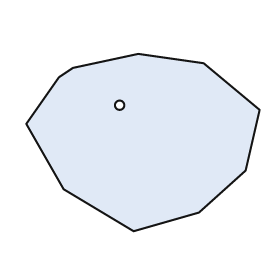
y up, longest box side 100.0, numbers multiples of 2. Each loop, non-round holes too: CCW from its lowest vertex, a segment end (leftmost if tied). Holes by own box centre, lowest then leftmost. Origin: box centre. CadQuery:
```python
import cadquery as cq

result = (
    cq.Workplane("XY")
    .moveTo(-4.0, -38.0)
    .lineTo(24.0, -30.0)
    .lineTo(44.0, -12.0)
    .lineTo(50.0, 14.0)
    .lineTo(26.0, 34.0)
    .lineTo(-2.0, 38.0)
    .lineTo(-30.0, 32.0)
    .lineTo(-36.0, 28.0)
    .lineTo(-50.0, 8.0)
    .lineTo(-34.0, -20.0)
    .close()
    .moveTo(-10.0, 16.0)
    .circle(2.0)
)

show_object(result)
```